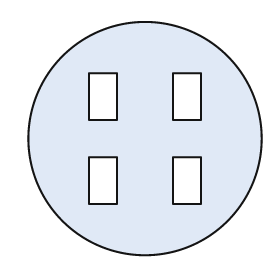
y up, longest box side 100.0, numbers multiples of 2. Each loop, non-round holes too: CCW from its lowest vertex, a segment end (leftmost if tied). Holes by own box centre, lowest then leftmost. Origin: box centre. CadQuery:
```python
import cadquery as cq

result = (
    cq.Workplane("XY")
    .moveTo(0.0, 0.0)
    .circle(50.0)
    .moveTo(-24.0, -28.0)
    .lineTo(-12.0, -28.0)
    .lineTo(-12.0, -8.0)
    .lineTo(-24.0, -8.0)
    .close()
    .moveTo(12.0, -28.0)
    .lineTo(24.0, -28.0)
    .lineTo(24.0, -8.0)
    .lineTo(12.0, -8.0)
    .close()
    .moveTo(-24.0, 8.0)
    .lineTo(-12.0, 8.0)
    .lineTo(-12.0, 28.0)
    .lineTo(-24.0, 28.0)
    .close()
    .moveTo(12.0, 8.0)
    .lineTo(24.0, 8.0)
    .lineTo(24.0, 28.0)
    .lineTo(12.0, 28.0)
    .close()
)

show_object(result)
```